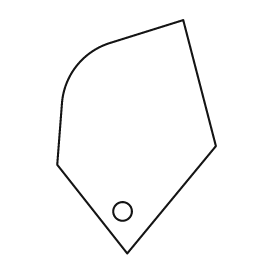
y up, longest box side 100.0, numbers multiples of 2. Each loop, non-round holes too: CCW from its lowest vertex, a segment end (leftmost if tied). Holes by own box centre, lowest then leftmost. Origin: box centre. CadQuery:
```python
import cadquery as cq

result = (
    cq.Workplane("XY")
    .moveTo(-4.0, -50.0)
    .lineTo(34.0, -4.0)
    .lineTo(20.0, 50.0)
    .lineTo(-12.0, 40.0)
    .threePointArc((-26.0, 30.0), (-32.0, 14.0))
    .lineTo(-34.0, -12.0)
    .close()
    .moveTo(-6.0, -32.0)
    .circle(4.0)
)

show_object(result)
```